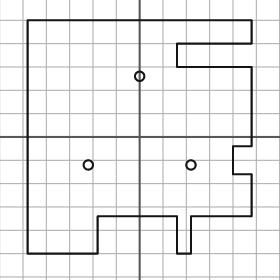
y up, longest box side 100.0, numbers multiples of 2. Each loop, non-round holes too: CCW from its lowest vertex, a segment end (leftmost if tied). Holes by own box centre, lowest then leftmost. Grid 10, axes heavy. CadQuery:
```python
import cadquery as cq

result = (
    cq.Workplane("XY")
    .moveTo(-48.0, -50.0)
    .lineTo(-18.0, -50.0)
    .lineTo(-18.0, -34.0)
    .lineTo(16.0, -34.0)
    .lineTo(16.0, -50.0)
    .lineTo(22.0, -50.0)
    .lineTo(22.0, -34.0)
    .lineTo(48.0, -34.0)
    .lineTo(48.0, -16.0)
    .lineTo(40.0, -16.0)
    .lineTo(40.0, -4.0)
    .lineTo(48.0, -4.0)
    .lineTo(48.0, 30.0)
    .lineTo(16.0, 30.0)
    .lineTo(16.0, 40.0)
    .lineTo(48.0, 40.0)
    .lineTo(48.0, 50.0)
    .lineTo(-48.0, 50.0)
    .close()
    .moveTo(-22.0, -12.0)
    .circle(2.0)
    .moveTo(22.0, -12.0)
    .circle(2.0)
    .moveTo(0.0, 26.0)
    .circle(2.0)
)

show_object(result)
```